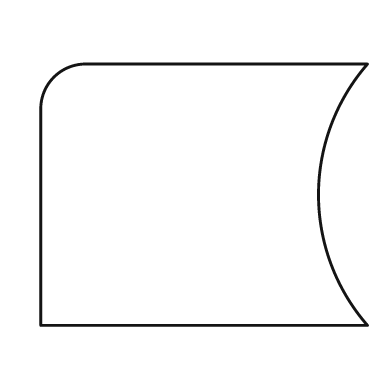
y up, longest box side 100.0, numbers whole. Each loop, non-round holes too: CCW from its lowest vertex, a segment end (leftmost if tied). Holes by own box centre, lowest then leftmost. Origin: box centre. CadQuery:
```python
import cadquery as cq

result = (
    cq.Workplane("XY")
    .moveTo(-50.0, -40.0)
    .lineTo(50.0, -40.0)
    .threePointArc((35.0, 0.0), (50.0, 40.0))
    .lineTo(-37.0, 40.0)
    .threePointArc((-46.0, 36.0), (-50.0, 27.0))
    .close()
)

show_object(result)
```